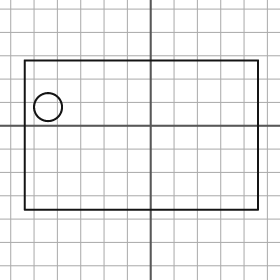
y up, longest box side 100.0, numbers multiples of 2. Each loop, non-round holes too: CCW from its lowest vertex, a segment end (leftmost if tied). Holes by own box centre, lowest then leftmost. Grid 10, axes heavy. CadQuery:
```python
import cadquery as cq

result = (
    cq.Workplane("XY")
    .moveTo(-54.0, -36.0)
    .lineTo(46.0, -36.0)
    .lineTo(46.0, 28.0)
    .lineTo(-54.0, 28.0)
    .close()
    .moveTo(-44.0, 8.0)
    .circle(6.0)
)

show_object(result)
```